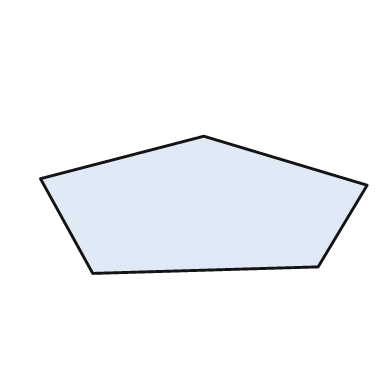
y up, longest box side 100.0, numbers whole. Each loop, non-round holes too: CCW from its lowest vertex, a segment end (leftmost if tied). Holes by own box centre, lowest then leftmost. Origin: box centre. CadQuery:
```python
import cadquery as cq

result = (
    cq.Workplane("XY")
    .moveTo(-34.0, -21.0)
    .lineTo(35.0, -19.0)
    .lineTo(50.0, 6.0)
    .lineTo(0.0, 21.0)
    .lineTo(-50.0, 8.0)
    .close()
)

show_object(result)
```